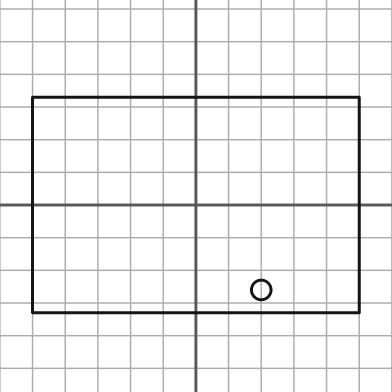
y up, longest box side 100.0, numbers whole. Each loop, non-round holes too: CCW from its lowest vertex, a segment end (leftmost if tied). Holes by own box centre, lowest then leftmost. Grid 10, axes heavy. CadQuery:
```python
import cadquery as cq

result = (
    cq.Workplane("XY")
    .moveTo(-50.0, -33.0)
    .lineTo(50.0, -33.0)
    .lineTo(50.0, 33.0)
    .lineTo(-50.0, 33.0)
    .close()
    .moveTo(20.0, -26.0)
    .circle(3.0)
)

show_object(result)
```